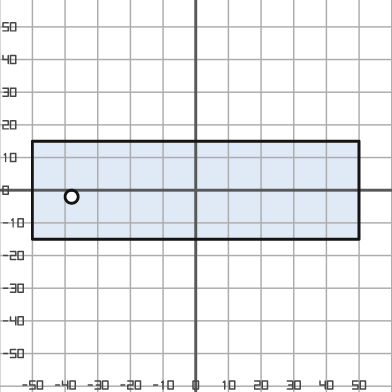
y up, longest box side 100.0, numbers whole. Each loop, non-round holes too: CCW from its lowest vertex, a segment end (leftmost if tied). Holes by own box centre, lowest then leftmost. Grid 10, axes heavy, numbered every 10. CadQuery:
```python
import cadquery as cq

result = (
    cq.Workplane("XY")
    .moveTo(-50.0, -15.0)
    .lineTo(50.0, -15.0)
    .lineTo(50.0, 15.0)
    .lineTo(-50.0, 15.0)
    .close()
    .moveTo(-38.0, -2.0)
    .circle(2.0)
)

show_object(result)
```